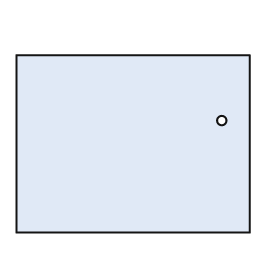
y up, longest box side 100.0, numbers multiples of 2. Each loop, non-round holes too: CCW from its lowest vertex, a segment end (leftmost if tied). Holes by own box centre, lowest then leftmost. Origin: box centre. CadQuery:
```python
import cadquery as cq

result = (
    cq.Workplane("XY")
    .moveTo(-50.0, -38.0)
    .lineTo(50.0, -38.0)
    .lineTo(50.0, 38.0)
    .lineTo(-50.0, 38.0)
    .close()
    .moveTo(38.0, 10.0)
    .circle(2.0)
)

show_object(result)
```